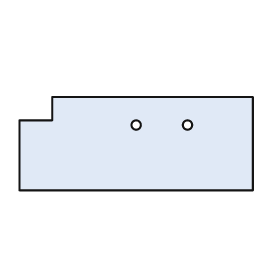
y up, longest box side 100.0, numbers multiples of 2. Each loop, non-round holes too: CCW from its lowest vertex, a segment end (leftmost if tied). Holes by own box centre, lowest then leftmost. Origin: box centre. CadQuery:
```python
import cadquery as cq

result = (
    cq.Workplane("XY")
    .moveTo(-50.0, -20.0)
    .lineTo(50.0, -20.0)
    .lineTo(50.0, 20.0)
    .lineTo(-36.0, 20.0)
    .lineTo(-36.0, 10.0)
    .lineTo(-50.0, 10.0)
    .close()
    .moveTo(0.0, 8.0)
    .circle(2.0)
    .moveTo(22.0, 8.0)
    .circle(2.0)
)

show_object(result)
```